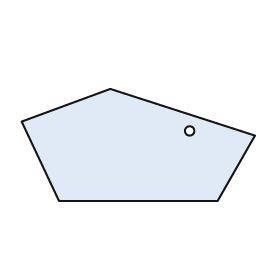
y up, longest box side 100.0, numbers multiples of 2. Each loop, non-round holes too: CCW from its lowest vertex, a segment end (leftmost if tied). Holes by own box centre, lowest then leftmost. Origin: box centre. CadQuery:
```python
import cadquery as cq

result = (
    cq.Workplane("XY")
    .moveTo(-34.0, -24.0)
    .lineTo(34.0, -24.0)
    .lineTo(50.0, 4.0)
    .lineTo(-12.0, 24.0)
    .lineTo(-50.0, 10.0)
    .close()
    .moveTo(22.0, 6.0)
    .circle(2.0)
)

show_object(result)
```